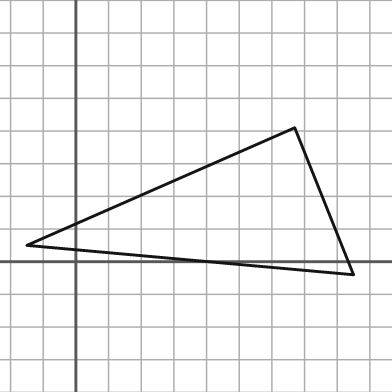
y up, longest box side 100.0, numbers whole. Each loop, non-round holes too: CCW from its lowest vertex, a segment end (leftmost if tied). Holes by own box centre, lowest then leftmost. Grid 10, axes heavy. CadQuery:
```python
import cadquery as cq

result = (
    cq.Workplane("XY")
    .moveTo(85.0, -4.0)
    .lineTo(67.0, 41.0)
    .lineTo(-15.0, 5.0)
    .close()
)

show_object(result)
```